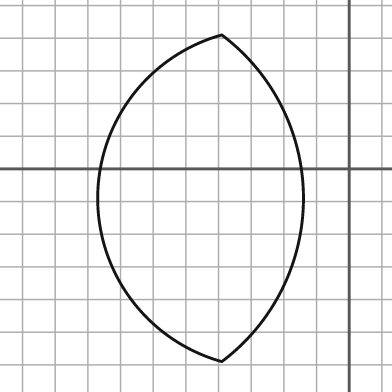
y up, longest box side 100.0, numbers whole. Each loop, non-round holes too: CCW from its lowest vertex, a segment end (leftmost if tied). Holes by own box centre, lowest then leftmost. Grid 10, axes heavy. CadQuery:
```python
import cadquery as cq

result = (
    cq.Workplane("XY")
    .moveTo(-39.0, -59.0)
    .threePointArc((-14.0, -9.0), (-39.0, 41.0))
    .threePointArc((-77.0, -9.0), (-39.0, -59.0))
    .close()
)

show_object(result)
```